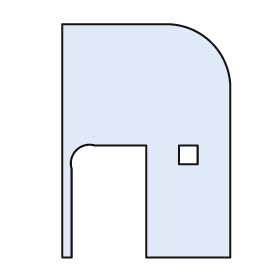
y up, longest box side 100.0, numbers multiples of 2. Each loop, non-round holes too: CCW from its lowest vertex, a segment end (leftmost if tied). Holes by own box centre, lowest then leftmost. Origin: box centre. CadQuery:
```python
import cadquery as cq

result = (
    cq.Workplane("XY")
    .moveTo(-36.0, -50.0)
    .lineTo(-32.0, -50.0)
    .lineTo(-32.0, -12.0)
    .threePointArc((-30.0, -4.0), (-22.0, -2.0))
    .lineTo(0.0, -2.0)
    .lineTo(0.0, -50.0)
    .lineTo(36.0, -50.0)
    .lineTo(36.0, 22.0)
    .threePointArc((28.0, 42.0), (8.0, 50.0))
    .lineTo(-36.0, 50.0)
    .close()
    .moveTo(14.0, -10.0)
    .lineTo(22.0, -10.0)
    .lineTo(22.0, -2.0)
    .lineTo(14.0, -2.0)
    .close()
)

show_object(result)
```